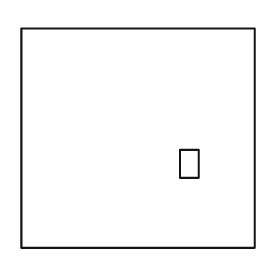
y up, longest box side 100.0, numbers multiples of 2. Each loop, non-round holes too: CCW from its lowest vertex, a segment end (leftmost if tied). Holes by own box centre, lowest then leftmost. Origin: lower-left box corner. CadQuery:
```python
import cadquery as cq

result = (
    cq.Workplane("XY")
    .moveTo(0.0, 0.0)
    .lineTo(100.0, 0.0)
    .lineTo(100.0, 94.0)
    .lineTo(0.0, 94.0)
    .close()
    .moveTo(68.0, 30.0)
    .lineTo(76.0, 30.0)
    .lineTo(76.0, 42.0)
    .lineTo(68.0, 42.0)
    .close()
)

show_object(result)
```